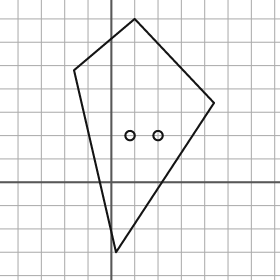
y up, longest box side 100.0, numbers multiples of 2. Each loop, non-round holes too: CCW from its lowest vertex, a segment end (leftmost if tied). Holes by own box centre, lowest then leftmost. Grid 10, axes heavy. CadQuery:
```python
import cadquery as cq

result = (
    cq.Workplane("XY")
    .moveTo(2.0, -30.0)
    .lineTo(44.0, 34.0)
    .lineTo(10.0, 70.0)
    .lineTo(-16.0, 48.0)
    .close()
    .moveTo(8.0, 20.0)
    .circle(2.0)
    .moveTo(20.0, 20.0)
    .circle(2.0)
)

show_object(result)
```